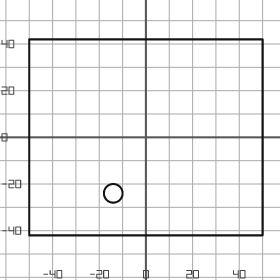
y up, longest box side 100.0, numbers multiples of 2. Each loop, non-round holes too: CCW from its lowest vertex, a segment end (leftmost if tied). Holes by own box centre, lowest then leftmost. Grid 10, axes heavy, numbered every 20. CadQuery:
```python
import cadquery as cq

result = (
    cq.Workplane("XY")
    .moveTo(-50.0, -42.0)
    .lineTo(50.0, -42.0)
    .lineTo(50.0, 42.0)
    .lineTo(-50.0, 42.0)
    .close()
    .moveTo(-14.0, -24.0)
    .circle(4.0)
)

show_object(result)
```